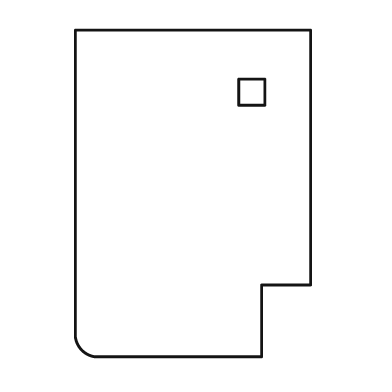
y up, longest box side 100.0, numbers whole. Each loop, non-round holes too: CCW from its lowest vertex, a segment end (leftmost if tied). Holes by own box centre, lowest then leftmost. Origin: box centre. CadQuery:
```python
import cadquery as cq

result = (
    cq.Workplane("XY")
    .moveTo(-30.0, -50.0)
    .lineTo(21.0, -50.0)
    .lineTo(21.0, -28.0)
    .lineTo(36.0, -28.0)
    .lineTo(36.0, 50.0)
    .lineTo(-36.0, 50.0)
    .lineTo(-36.0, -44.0)
    .threePointArc((-34.0, -48.0), (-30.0, -50.0))
    .close()
    .moveTo(14.0, 27.0)
    .lineTo(22.0, 27.0)
    .lineTo(22.0, 35.0)
    .lineTo(14.0, 35.0)
    .close()
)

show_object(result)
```